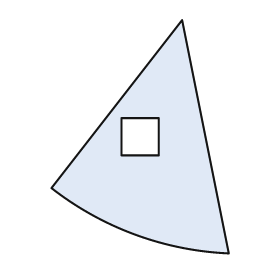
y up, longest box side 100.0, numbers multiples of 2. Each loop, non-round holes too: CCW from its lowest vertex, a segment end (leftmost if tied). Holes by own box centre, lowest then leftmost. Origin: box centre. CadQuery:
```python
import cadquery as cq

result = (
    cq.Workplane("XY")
    .moveTo(38.0, -50.0)
    .lineTo(18.0, 50.0)
    .lineTo(-38.0, -22.0)
    .threePointArc((-2.0, -42.0), (38.0, -50.0))
    .close()
    .moveTo(-8.0, -8.0)
    .lineTo(8.0, -8.0)
    .lineTo(8.0, 8.0)
    .lineTo(-8.0, 8.0)
    .close()
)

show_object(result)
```